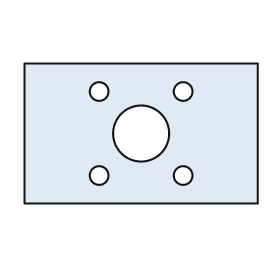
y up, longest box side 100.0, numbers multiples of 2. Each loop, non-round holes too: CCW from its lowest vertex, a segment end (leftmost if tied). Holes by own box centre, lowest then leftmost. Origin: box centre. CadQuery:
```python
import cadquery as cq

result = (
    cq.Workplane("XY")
    .moveTo(-50.0, -30.0)
    .lineTo(50.0, -30.0)
    .lineTo(50.0, 30.0)
    .lineTo(-50.0, 30.0)
    .close()
    .moveTo(-18.0, -18.0)
    .circle(4.0)
    .moveTo(18.0, -18.0)
    .circle(4.0)
    .moveTo(0.0, 0.0)
    .circle(12.0)
    .moveTo(-18.0, 18.0)
    .circle(4.0)
    .moveTo(18.0, 18.0)
    .circle(4.0)
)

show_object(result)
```